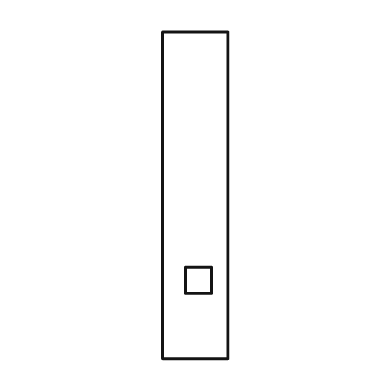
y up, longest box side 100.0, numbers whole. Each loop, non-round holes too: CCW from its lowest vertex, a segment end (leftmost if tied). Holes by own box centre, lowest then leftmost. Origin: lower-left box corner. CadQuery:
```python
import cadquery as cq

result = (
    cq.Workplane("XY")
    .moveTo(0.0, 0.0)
    .lineTo(20.0, 0.0)
    .lineTo(20.0, 100.0)
    .lineTo(0.0, 100.0)
    .close()
    .moveTo(7.0, 20.0)
    .lineTo(15.0, 20.0)
    .lineTo(15.0, 28.0)
    .lineTo(7.0, 28.0)
    .close()
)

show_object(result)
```